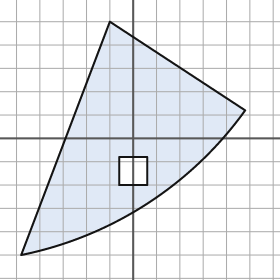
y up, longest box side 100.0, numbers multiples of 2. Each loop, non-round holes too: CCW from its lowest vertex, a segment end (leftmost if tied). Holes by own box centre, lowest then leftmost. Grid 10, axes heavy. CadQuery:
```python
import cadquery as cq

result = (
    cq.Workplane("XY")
    .moveTo(-48.0, -50.0)
    .threePointArc((6.0, -28.0), (48.0, 12.0))
    .lineTo(-10.0, 50.0)
    .close()
    .moveTo(-6.0, -20.0)
    .lineTo(6.0, -20.0)
    .lineTo(6.0, -8.0)
    .lineTo(-6.0, -8.0)
    .close()
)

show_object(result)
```